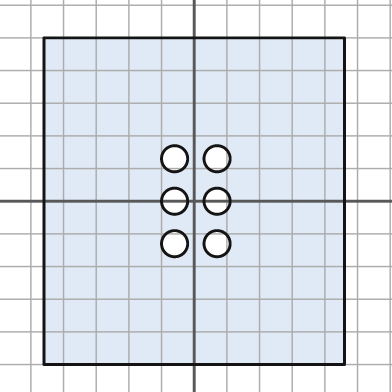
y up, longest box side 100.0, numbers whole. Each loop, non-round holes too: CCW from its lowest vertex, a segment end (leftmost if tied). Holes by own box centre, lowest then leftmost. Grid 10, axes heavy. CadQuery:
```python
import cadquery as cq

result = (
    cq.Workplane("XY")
    .moveTo(-46.0, -50.0)
    .lineTo(46.0, -50.0)
    .lineTo(46.0, 50.0)
    .lineTo(-46.0, 50.0)
    .close()
    .moveTo(-6.0, -13.0)
    .circle(4.0)
    .moveTo(7.0, -13.0)
    .circle(4.0)
    .moveTo(-6.0, 0.0)
    .circle(4.0)
    .moveTo(7.0, 0.0)
    .circle(4.0)
    .moveTo(-6.0, 13.0)
    .circle(4.0)
    .moveTo(7.0, 13.0)
    .circle(4.0)
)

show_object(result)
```